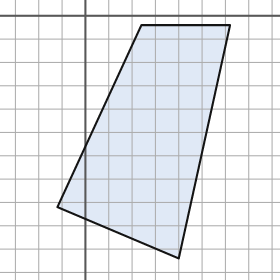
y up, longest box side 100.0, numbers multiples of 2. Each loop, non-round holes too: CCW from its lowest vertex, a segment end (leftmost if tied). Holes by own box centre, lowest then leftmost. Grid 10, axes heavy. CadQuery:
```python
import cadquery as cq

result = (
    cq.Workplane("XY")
    .moveTo(40.0, -104.0)
    .lineTo(62.0, -4.0)
    .lineTo(24.0, -4.0)
    .lineTo(-12.0, -82.0)
    .close()
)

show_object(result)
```